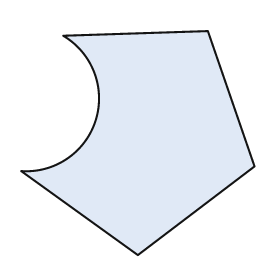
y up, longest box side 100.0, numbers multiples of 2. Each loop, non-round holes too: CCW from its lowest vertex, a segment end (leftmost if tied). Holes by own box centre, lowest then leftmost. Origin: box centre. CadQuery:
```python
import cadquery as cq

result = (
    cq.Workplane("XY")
    .moveTo(0.0, -48.0)
    .lineTo(50.0, -10.0)
    .lineTo(30.0, 48.0)
    .lineTo(-32.0, 46.0)
    .threePointArc((-18.0, 10.0), (-50.0, -12.0))
    .close()
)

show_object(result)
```